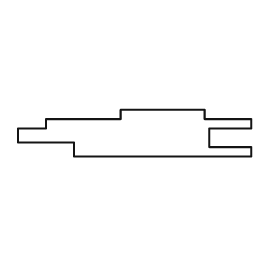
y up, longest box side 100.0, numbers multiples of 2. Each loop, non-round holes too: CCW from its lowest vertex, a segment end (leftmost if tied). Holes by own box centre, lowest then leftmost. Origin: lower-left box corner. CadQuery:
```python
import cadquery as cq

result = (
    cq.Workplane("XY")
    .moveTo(24.0, 0.0)
    .lineTo(100.0, 0.0)
    .lineTo(100.0, 4.0)
    .lineTo(82.0, 4.0)
    .lineTo(82.0, 12.0)
    .lineTo(100.0, 12.0)
    .lineTo(100.0, 16.0)
    .lineTo(80.0, 16.0)
    .lineTo(80.0, 20.0)
    .lineTo(44.0, 20.0)
    .lineTo(44.0, 16.0)
    .lineTo(12.0, 16.0)
    .lineTo(12.0, 12.0)
    .lineTo(0.0, 12.0)
    .lineTo(0.0, 6.0)
    .lineTo(24.0, 6.0)
    .close()
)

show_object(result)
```